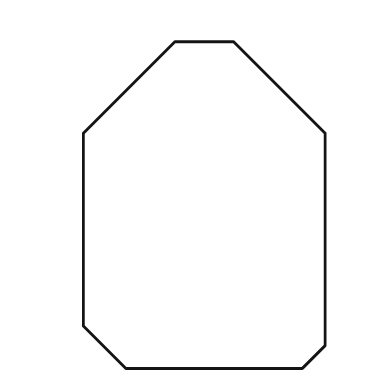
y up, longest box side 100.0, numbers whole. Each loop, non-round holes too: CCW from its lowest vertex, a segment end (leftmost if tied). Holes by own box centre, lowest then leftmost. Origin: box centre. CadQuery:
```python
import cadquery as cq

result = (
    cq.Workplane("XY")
    .moveTo(-24.0, -50.0)
    .lineTo(30.0, -50.0)
    .lineTo(37.0, -43.0)
    .lineTo(37.0, 22.0)
    .lineTo(9.0, 50.0)
    .lineTo(-9.0, 50.0)
    .lineTo(-37.0, 22.0)
    .lineTo(-37.0, -37.0)
    .close()
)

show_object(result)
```